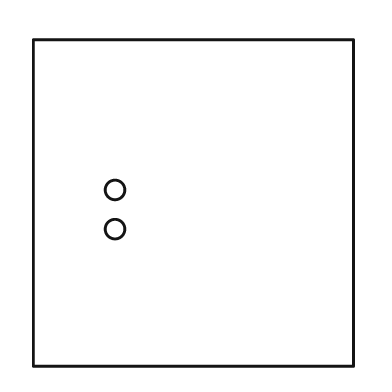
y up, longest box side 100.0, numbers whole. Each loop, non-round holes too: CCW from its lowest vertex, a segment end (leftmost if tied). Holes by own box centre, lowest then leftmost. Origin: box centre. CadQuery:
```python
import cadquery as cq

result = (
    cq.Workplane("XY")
    .moveTo(-49.0, -50.0)
    .lineTo(49.0, -50.0)
    .lineTo(49.0, 50.0)
    .lineTo(-49.0, 50.0)
    .close()
    .moveTo(-24.0, -8.0)
    .circle(3.0)
    .moveTo(-24.0, 4.0)
    .circle(3.0)
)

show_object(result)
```